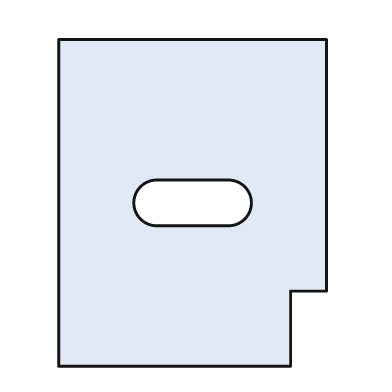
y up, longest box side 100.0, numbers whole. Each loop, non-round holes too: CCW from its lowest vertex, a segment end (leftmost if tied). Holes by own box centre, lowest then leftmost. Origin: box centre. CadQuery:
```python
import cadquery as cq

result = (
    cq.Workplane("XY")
    .moveTo(-41.0, -50.0)
    .lineTo(30.0, -50.0)
    .lineTo(30.0, -27.0)
    .lineTo(41.0, -27.0)
    .lineTo(41.0, 50.0)
    .lineTo(-41.0, 50.0)
    .close()
    .moveTo(-11.0, -7.0)
    .lineTo(11.0, -7.0)
    .threePointArc((18.0, 0.0), (11.0, 7.0))
    .lineTo(-11.0, 7.0)
    .threePointArc((-18.0, 0.0), (-11.0, -7.0))
    .close()
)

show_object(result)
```